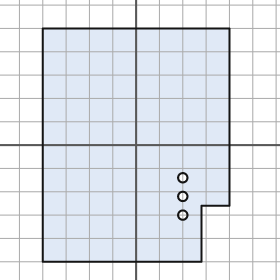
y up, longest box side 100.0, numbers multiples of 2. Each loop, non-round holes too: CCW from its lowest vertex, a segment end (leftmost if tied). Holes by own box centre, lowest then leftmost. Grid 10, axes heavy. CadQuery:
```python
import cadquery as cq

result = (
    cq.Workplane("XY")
    .moveTo(-40.0, -50.0)
    .lineTo(28.0, -50.0)
    .lineTo(28.0, -26.0)
    .lineTo(40.0, -26.0)
    .lineTo(40.0, 50.0)
    .lineTo(-40.0, 50.0)
    .close()
    .moveTo(20.0, -30.0)
    .circle(2.0)
    .moveTo(20.0, -22.0)
    .circle(2.0)
    .moveTo(20.0, -14.0)
    .circle(2.0)
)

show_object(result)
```